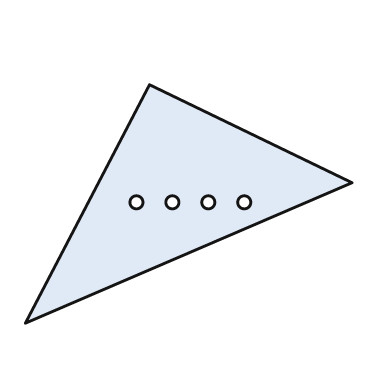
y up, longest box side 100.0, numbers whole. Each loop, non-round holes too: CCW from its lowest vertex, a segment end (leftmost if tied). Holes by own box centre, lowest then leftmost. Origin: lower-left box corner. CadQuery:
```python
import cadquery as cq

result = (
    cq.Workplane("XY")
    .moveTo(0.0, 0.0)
    .lineTo(100.0, 43.0)
    .lineTo(38.0, 73.0)
    .close()
    .moveTo(34.0, 37.0)
    .circle(2.0)
    .moveTo(45.0, 37.0)
    .circle(2.0)
    .moveTo(56.0, 37.0)
    .circle(2.0)
    .moveTo(67.0, 37.0)
    .circle(2.0)
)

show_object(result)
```